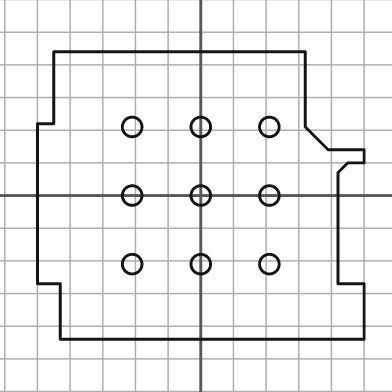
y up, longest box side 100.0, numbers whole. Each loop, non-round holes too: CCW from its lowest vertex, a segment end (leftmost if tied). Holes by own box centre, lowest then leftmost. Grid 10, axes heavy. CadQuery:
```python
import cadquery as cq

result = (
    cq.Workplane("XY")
    .moveTo(-43.0, -44.0)
    .lineTo(50.0, -44.0)
    .lineTo(50.0, -27.0)
    .lineTo(42.0, -27.0)
    .lineTo(42.0, 7.0)
    .lineTo(45.0, 10.0)
    .lineTo(50.0, 10.0)
    .lineTo(50.0, 14.0)
    .lineTo(39.0, 14.0)
    .lineTo(32.0, 21.0)
    .lineTo(32.0, 44.0)
    .lineTo(-45.0, 44.0)
    .lineTo(-45.0, 22.0)
    .lineTo(-50.0, 22.0)
    .lineTo(-50.0, -27.0)
    .lineTo(-43.0, -27.0)
    .close()
    .moveTo(-21.0, -21.0)
    .circle(3.0)
    .moveTo(0.0, -21.0)
    .circle(3.0)
    .moveTo(21.0, -21.0)
    .circle(3.0)
    .moveTo(-21.0, 0.0)
    .circle(3.0)
    .moveTo(0.0, 0.0)
    .circle(3.0)
    .moveTo(21.0, 0.0)
    .circle(3.0)
    .moveTo(-21.0, 21.0)
    .circle(3.0)
    .moveTo(0.0, 21.0)
    .circle(3.0)
    .moveTo(21.0, 21.0)
    .circle(3.0)
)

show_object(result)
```